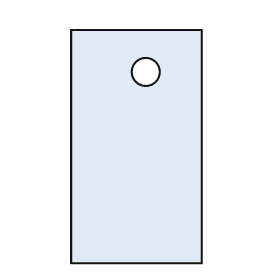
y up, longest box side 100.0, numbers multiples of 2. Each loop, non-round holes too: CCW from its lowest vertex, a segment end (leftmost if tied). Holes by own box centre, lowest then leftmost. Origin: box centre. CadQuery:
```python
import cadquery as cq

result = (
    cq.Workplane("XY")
    .moveTo(-28.0, -50.0)
    .lineTo(28.0, -50.0)
    .lineTo(28.0, 50.0)
    .lineTo(-28.0, 50.0)
    .close()
    .moveTo(4.0, 32.0)
    .circle(6.0)
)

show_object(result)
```